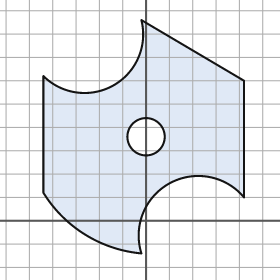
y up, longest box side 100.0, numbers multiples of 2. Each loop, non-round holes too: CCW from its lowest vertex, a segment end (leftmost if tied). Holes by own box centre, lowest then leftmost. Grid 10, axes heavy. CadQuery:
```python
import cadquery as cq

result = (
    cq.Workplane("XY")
    .moveTo(-2.0, -14.0)
    .threePointArc((10.0, 16.0), (42.0, 10.0))
    .lineTo(42.0, 60.0)
    .lineTo(-2.0, 86.0)
    .threePointArc((-14.0, 58.0), (-44.0, 62.0))
    .lineTo(-44.0, 12.0)
    .threePointArc((-26.0, -6.0), (-2.0, -14.0))
    .close()
    .moveTo(0.0, 36.0)
    .circle(8.0)
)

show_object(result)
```